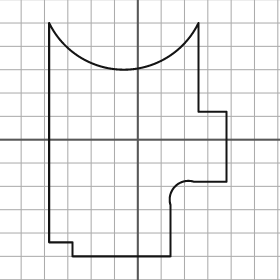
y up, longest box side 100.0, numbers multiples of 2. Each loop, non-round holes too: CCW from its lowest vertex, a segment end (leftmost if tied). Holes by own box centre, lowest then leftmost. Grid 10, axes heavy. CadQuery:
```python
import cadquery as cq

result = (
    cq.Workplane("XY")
    .moveTo(-28.0, -50.0)
    .lineTo(14.0, -50.0)
    .lineTo(14.0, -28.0)
    .threePointArc((16.0, -20.0), (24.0, -18.0))
    .lineTo(38.0, -18.0)
    .lineTo(38.0, 12.0)
    .lineTo(26.0, 12.0)
    .lineTo(26.0, 50.0)
    .threePointArc((-6.0, 30.0), (-38.0, 50.0))
    .lineTo(-38.0, -44.0)
    .lineTo(-28.0, -44.0)
    .close()
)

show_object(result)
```